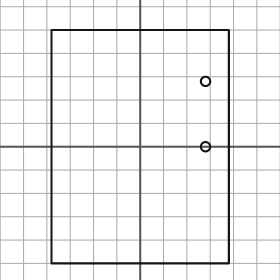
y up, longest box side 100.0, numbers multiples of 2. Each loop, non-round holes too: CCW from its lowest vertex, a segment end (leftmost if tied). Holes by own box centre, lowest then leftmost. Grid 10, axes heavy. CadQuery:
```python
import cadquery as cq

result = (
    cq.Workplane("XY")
    .moveTo(-38.0, -50.0)
    .lineTo(38.0, -50.0)
    .lineTo(38.0, 50.0)
    .lineTo(-38.0, 50.0)
    .close()
    .moveTo(28.0, 0.0)
    .circle(2.0)
    .moveTo(28.0, 28.0)
    .circle(2.0)
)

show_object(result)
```